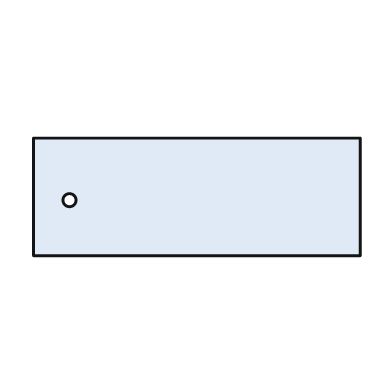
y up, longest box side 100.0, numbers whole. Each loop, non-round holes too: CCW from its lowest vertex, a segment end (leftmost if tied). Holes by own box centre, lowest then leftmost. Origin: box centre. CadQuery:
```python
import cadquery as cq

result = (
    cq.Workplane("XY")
    .moveTo(-50.0, -18.0)
    .lineTo(50.0, -18.0)
    .lineTo(50.0, 18.0)
    .lineTo(-50.0, 18.0)
    .close()
    .moveTo(-39.0, -1.0)
    .circle(2.0)
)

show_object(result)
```